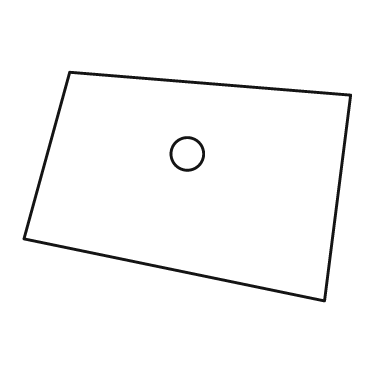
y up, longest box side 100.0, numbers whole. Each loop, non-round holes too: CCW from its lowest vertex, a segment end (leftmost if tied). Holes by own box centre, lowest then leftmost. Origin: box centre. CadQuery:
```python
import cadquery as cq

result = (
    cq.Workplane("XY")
    .moveTo(42.0, -35.0)
    .lineTo(50.0, 28.0)
    .lineTo(-36.0, 35.0)
    .lineTo(-50.0, -16.0)
    .close()
    .moveTo(0.0, 10.0)
    .circle(5.0)
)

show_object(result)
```